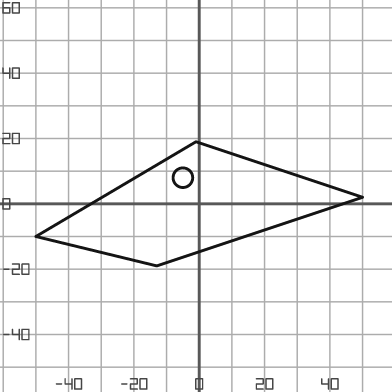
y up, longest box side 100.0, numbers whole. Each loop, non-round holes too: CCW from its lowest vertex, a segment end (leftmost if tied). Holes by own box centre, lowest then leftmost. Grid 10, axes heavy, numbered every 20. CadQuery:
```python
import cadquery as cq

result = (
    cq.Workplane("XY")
    .moveTo(-13.0, -19.0)
    .lineTo(50.0, 2.0)
    .lineTo(-1.0, 19.0)
    .lineTo(-50.0, -10.0)
    .close()
    .moveTo(-5.0, 8.0)
    .circle(3.0)
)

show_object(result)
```